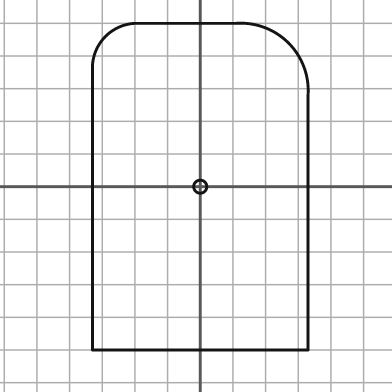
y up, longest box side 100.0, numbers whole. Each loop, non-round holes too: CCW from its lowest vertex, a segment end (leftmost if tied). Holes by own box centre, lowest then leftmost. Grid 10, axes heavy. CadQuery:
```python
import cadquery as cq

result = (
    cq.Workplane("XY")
    .moveTo(-33.0, -50.0)
    .lineTo(33.0, -50.0)
    .lineTo(33.0, 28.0)
    .threePointArc((27.0, 44.0), (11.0, 50.0))
    .lineTo(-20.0, 50.0)
    .threePointArc((-29.0, 46.0), (-33.0, 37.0))
    .close()
    .moveTo(0.0, 0.0)
    .circle(2.0)
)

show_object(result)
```